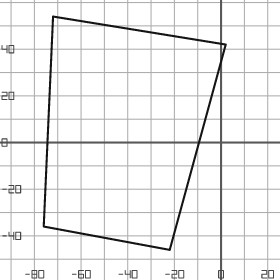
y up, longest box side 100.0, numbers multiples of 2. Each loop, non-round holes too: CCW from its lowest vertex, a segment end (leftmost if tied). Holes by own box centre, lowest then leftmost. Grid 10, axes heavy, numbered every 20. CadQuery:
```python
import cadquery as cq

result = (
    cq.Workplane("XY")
    .moveTo(-22.0, -46.0)
    .lineTo(2.0, 42.0)
    .lineTo(-72.0, 54.0)
    .lineTo(-76.0, -36.0)
    .close()
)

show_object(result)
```